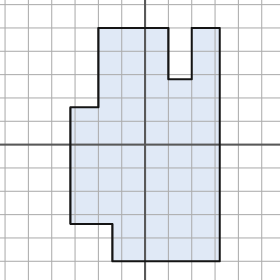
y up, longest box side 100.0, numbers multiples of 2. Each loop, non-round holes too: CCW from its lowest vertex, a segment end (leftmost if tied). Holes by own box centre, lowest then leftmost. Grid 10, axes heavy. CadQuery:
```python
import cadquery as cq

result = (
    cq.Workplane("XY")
    .moveTo(-14.0, -50.0)
    .lineTo(32.0, -50.0)
    .lineTo(32.0, 50.0)
    .lineTo(20.0, 50.0)
    .lineTo(20.0, 28.0)
    .lineTo(10.0, 28.0)
    .lineTo(10.0, 50.0)
    .lineTo(-20.0, 50.0)
    .lineTo(-20.0, 16.0)
    .lineTo(-32.0, 16.0)
    .lineTo(-32.0, -34.0)
    .lineTo(-14.0, -34.0)
    .close()
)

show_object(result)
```